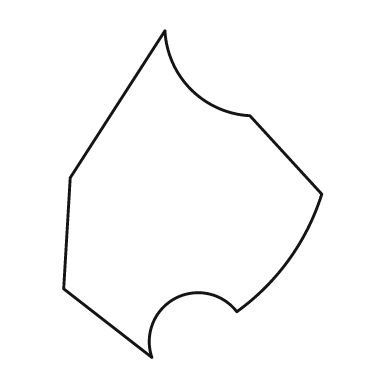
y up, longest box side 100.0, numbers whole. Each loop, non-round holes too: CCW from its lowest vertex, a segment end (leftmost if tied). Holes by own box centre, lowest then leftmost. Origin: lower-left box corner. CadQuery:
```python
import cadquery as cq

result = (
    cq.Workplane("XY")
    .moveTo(27.0, 0.0)
    .threePointArc((34.0, 18.0), (53.0, 14.0))
    .threePointArc((69.0, 30.0), (79.0, 50.0))
    .lineTo(57.0, 74.0)
    .threePointArc((39.0, 82.0), (31.0, 100.0))
    .lineTo(2.0, 55.0)
    .lineTo(0.0, 21.0)
    .close()
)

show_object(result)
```